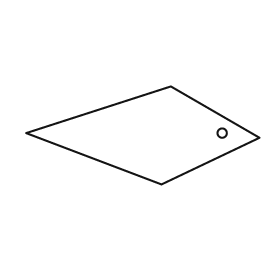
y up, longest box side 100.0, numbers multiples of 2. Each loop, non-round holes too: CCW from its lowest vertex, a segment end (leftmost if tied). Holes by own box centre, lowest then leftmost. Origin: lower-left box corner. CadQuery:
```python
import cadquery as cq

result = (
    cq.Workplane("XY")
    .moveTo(58.0, 0.0)
    .lineTo(100.0, 20.0)
    .lineTo(62.0, 42.0)
    .lineTo(0.0, 22.0)
    .close()
    .moveTo(84.0, 22.0)
    .circle(2.0)
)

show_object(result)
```